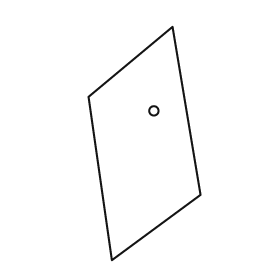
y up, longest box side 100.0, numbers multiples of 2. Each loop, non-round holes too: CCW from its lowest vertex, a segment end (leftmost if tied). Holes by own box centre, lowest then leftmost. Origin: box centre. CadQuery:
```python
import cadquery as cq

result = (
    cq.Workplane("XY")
    .moveTo(-14.0, -50.0)
    .lineTo(24.0, -22.0)
    .lineTo(12.0, 50.0)
    .lineTo(-24.0, 20.0)
    .close()
    .moveTo(4.0, 14.0)
    .circle(2.0)
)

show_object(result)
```